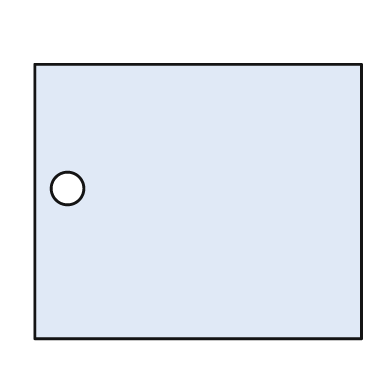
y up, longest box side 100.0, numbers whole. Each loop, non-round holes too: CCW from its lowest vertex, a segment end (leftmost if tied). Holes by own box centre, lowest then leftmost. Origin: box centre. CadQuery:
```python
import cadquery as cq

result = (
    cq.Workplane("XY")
    .moveTo(-50.0, -42.0)
    .lineTo(50.0, -42.0)
    .lineTo(50.0, 42.0)
    .lineTo(-50.0, 42.0)
    .close()
    .moveTo(-40.0, 4.0)
    .circle(5.0)
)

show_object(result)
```